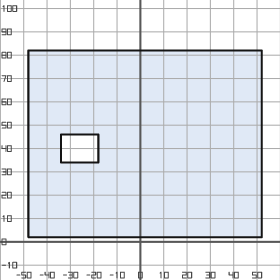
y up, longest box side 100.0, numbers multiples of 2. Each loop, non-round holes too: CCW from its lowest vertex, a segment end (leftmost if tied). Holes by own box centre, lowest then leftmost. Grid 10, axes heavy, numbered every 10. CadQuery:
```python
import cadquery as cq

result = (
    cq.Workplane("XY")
    .moveTo(-48.0, 2.0)
    .lineTo(52.0, 2.0)
    .lineTo(52.0, 82.0)
    .lineTo(-48.0, 82.0)
    .close()
    .moveTo(-34.0, 34.0)
    .lineTo(-18.0, 34.0)
    .lineTo(-18.0, 46.0)
    .lineTo(-34.0, 46.0)
    .close()
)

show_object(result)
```